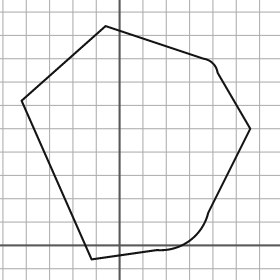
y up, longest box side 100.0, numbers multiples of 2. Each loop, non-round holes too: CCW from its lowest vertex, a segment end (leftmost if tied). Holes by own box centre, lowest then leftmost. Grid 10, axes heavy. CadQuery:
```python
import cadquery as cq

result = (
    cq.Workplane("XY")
    .moveTo(-12.0, -6.0)
    .lineTo(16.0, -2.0)
    .threePointArc((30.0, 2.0), (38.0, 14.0))
    .lineTo(56.0, 50.0)
    .lineTo(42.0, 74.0)
    .threePointArc((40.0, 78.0), (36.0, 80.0))
    .lineTo(-6.0, 94.0)
    .lineTo(-42.0, 62.0)
    .close()
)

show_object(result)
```